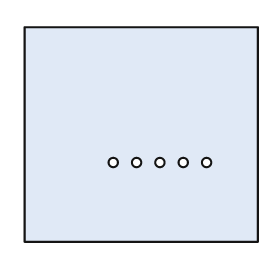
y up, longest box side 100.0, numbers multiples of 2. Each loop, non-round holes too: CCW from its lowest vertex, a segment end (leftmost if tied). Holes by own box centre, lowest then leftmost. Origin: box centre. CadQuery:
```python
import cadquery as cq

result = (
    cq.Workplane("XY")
    .moveTo(-50.0, -46.0)
    .lineTo(50.0, -46.0)
    .lineTo(50.0, 46.0)
    .lineTo(-50.0, 46.0)
    .close()
    .moveTo(-12.0, -12.0)
    .circle(2.0)
    .moveTo(-2.0, -12.0)
    .circle(2.0)
    .moveTo(8.0, -12.0)
    .circle(2.0)
    .moveTo(18.0, -12.0)
    .circle(2.0)
    .moveTo(28.0, -12.0)
    .circle(2.0)
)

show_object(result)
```